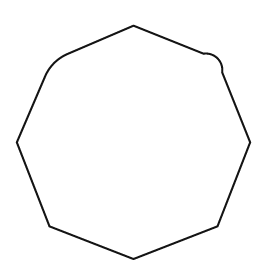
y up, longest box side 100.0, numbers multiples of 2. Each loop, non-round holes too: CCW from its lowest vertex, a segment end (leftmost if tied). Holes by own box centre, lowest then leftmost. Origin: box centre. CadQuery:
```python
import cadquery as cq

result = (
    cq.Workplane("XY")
    .moveTo(0.0, -50.0)
    .lineTo(36.0, -36.0)
    .lineTo(50.0, 0.0)
    .lineTo(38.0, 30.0)
    .threePointArc((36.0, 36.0), (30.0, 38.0))
    .lineTo(0.0, 50.0)
    .lineTo(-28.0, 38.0)
    .threePointArc((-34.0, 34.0), (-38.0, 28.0))
    .lineTo(-50.0, 0.0)
    .lineTo(-36.0, -36.0)
    .close()
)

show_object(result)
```